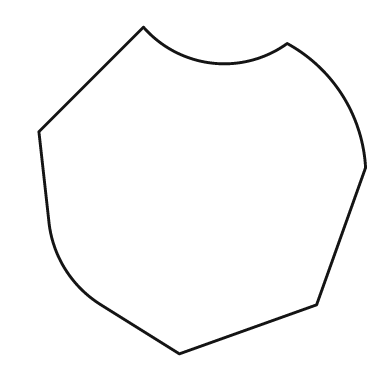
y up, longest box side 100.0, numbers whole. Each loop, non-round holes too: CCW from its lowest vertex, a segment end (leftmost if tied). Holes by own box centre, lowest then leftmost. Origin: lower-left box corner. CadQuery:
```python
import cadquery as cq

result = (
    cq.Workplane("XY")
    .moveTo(43.0, 0.0)
    .lineTo(85.0, 15.0)
    .lineTo(100.0, 57.0)
    .threePointArc((93.0, 79.0), (76.0, 95.0))
    .threePointArc((53.0, 89.0), (32.0, 100.0))
    .lineTo(0.0, 68.0)
    .lineTo(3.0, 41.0)
    .threePointArc((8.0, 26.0), (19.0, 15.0))
    .close()
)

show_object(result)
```